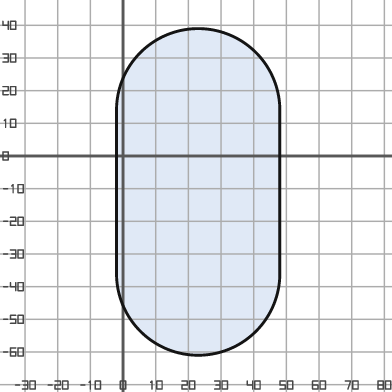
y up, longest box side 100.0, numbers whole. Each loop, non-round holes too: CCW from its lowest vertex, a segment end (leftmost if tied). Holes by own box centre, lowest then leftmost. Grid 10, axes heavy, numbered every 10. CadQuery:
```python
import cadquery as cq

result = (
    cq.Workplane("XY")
    .moveTo(-2.0, -36.0)
    .threePointArc((23.0, -61.0), (48.0, -36.0))
    .lineTo(48.0, 14.0)
    .threePointArc((23.0, 39.0), (-2.0, 14.0))
    .close()
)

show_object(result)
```